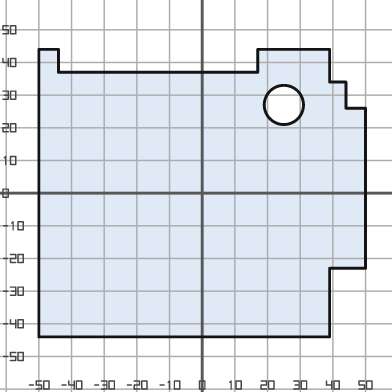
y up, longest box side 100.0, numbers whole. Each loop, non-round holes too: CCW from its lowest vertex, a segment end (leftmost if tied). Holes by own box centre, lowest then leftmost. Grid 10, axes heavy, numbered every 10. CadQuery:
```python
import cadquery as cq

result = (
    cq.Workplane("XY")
    .moveTo(-50.0, -44.0)
    .lineTo(39.0, -44.0)
    .lineTo(39.0, -23.0)
    .lineTo(50.0, -23.0)
    .lineTo(50.0, 26.0)
    .lineTo(44.0, 26.0)
    .lineTo(44.0, 34.0)
    .lineTo(39.0, 34.0)
    .lineTo(39.0, 44.0)
    .lineTo(17.0, 44.0)
    .lineTo(17.0, 37.0)
    .lineTo(-44.0, 37.0)
    .lineTo(-44.0, 44.0)
    .lineTo(-50.0, 44.0)
    .close()
    .moveTo(25.0, 27.0)
    .circle(6.0)
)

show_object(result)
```